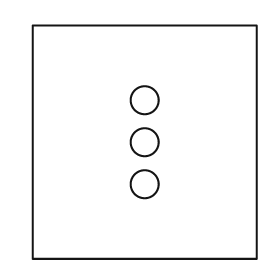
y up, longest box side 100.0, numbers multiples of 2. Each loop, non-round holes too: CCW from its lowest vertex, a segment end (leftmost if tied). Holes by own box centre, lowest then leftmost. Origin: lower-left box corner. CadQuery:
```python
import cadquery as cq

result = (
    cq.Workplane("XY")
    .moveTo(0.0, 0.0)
    .lineTo(96.0, 0.0)
    .lineTo(96.0, 100.0)
    .lineTo(0.0, 100.0)
    .close()
    .moveTo(48.0, 32.0)
    .circle(6.0)
    .moveTo(48.0, 50.0)
    .circle(6.0)
    .moveTo(48.0, 68.0)
    .circle(6.0)
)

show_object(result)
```